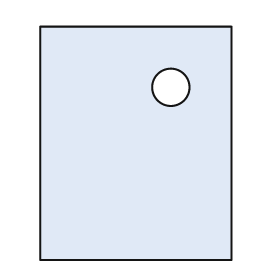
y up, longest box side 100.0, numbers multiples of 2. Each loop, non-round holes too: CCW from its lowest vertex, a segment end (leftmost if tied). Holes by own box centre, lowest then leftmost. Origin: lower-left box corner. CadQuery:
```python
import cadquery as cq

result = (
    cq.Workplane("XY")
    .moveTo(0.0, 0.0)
    .lineTo(82.0, 0.0)
    .lineTo(82.0, 100.0)
    .lineTo(0.0, 100.0)
    .close()
    .moveTo(56.0, 74.0)
    .circle(8.0)
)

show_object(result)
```